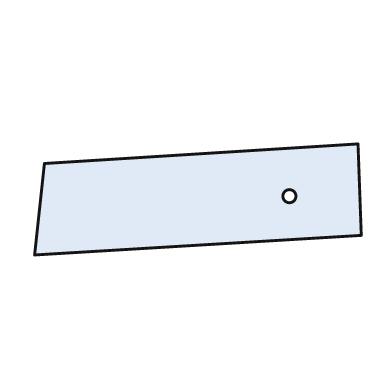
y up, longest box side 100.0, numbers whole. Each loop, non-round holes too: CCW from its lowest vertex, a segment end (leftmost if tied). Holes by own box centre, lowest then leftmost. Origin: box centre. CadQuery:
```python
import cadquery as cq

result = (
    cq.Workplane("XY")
    .moveTo(-50.0, -17.0)
    .lineTo(50.0, -11.0)
    .lineTo(49.0, 17.0)
    .lineTo(-47.0, 11.0)
    .close()
    .moveTo(28.0, 1.0)
    .circle(2.0)
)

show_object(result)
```